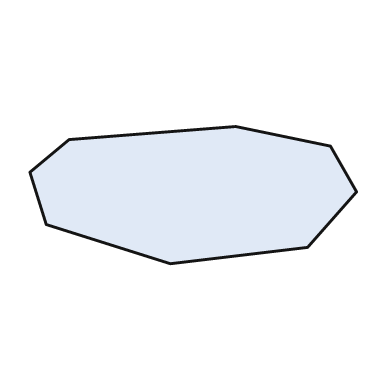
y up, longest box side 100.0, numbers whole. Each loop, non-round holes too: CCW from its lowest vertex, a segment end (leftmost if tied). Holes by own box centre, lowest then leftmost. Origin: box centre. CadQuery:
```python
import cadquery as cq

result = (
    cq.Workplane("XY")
    .moveTo(-7.0, -21.0)
    .lineTo(35.0, -16.0)
    .lineTo(50.0, 1.0)
    .lineTo(42.0, 15.0)
    .lineTo(13.0, 21.0)
    .lineTo(-38.0, 17.0)
    .lineTo(-50.0, 7.0)
    .lineTo(-45.0, -9.0)
    .close()
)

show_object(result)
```